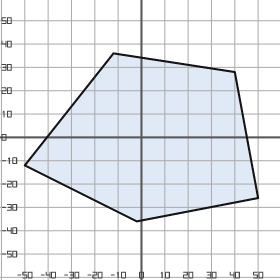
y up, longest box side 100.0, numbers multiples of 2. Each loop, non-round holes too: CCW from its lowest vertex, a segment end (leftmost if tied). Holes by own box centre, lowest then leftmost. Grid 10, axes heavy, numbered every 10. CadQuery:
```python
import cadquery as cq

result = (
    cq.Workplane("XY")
    .moveTo(-2.0, -36.0)
    .lineTo(50.0, -26.0)
    .lineTo(40.0, 28.0)
    .lineTo(-12.0, 36.0)
    .lineTo(-50.0, -12.0)
    .close()
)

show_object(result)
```